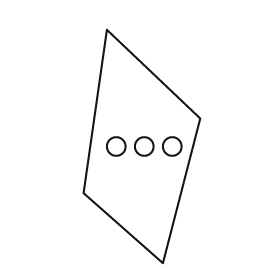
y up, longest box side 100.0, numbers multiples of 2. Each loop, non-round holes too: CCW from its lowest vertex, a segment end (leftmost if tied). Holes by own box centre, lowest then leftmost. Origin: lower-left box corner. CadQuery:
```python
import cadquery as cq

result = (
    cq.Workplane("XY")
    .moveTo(34.0, 0.0)
    .lineTo(50.0, 62.0)
    .lineTo(10.0, 100.0)
    .lineTo(0.0, 30.0)
    .close()
    .moveTo(14.0, 50.0)
    .circle(4.0)
    .moveTo(26.0, 50.0)
    .circle(4.0)
    .moveTo(38.0, 50.0)
    .circle(4.0)
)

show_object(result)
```